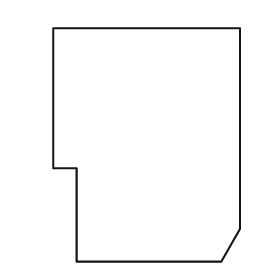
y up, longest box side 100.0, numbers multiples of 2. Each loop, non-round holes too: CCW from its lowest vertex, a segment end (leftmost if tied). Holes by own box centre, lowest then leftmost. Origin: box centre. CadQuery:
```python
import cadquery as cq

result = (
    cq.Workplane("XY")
    .moveTo(-30.0, -50.0)
    .lineTo(32.0, -50.0)
    .lineTo(40.0, -36.0)
    .lineTo(40.0, 50.0)
    .lineTo(-40.0, 50.0)
    .lineTo(-40.0, -10.0)
    .lineTo(-30.0, -10.0)
    .close()
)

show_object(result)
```